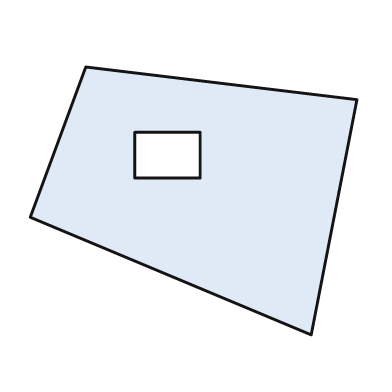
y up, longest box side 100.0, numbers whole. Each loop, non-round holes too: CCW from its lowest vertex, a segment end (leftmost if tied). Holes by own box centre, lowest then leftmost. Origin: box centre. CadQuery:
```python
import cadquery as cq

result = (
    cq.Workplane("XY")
    .moveTo(36.0, -41.0)
    .lineTo(50.0, 31.0)
    .lineTo(-33.0, 41.0)
    .lineTo(-50.0, -5.0)
    .close()
    .moveTo(-18.0, 7.0)
    .lineTo(2.0, 7.0)
    .lineTo(2.0, 21.0)
    .lineTo(-18.0, 21.0)
    .close()
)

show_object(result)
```